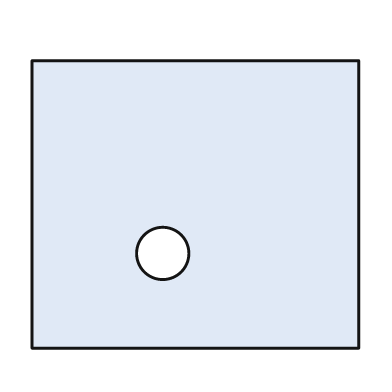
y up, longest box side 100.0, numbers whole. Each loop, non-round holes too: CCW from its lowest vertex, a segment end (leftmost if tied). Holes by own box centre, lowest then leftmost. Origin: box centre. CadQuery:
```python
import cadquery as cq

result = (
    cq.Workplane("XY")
    .moveTo(-50.0, -44.0)
    .lineTo(50.0, -44.0)
    .lineTo(50.0, 44.0)
    .lineTo(-50.0, 44.0)
    .close()
    .moveTo(-10.0, -15.0)
    .circle(8.0)
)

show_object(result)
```